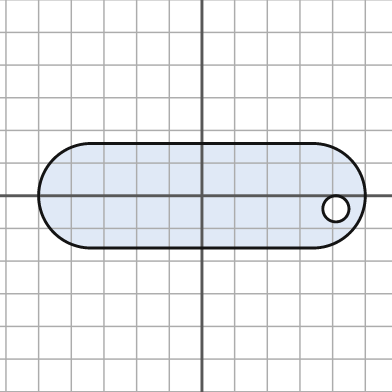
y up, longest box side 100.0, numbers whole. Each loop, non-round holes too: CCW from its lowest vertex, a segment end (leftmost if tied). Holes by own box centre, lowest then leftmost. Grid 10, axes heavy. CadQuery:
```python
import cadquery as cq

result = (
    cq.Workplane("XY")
    .moveTo(-34.0, -16.0)
    .lineTo(34.0, -16.0)
    .threePointArc((50.0, 0.0), (34.0, 16.0))
    .lineTo(-34.0, 16.0)
    .threePointArc((-50.0, 0.0), (-34.0, -16.0))
    .close()
    .moveTo(41.0, -4.0)
    .circle(4.0)
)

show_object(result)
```